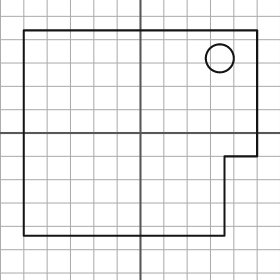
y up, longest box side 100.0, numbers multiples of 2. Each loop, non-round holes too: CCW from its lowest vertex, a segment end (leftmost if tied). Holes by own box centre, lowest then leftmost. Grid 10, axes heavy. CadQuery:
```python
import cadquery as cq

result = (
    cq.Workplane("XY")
    .moveTo(-50.0, -44.0)
    .lineTo(36.0, -44.0)
    .lineTo(36.0, -10.0)
    .lineTo(50.0, -10.0)
    .lineTo(50.0, 44.0)
    .lineTo(-50.0, 44.0)
    .close()
    .moveTo(34.0, 32.0)
    .circle(6.0)
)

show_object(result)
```